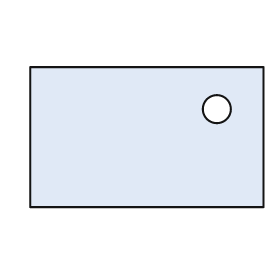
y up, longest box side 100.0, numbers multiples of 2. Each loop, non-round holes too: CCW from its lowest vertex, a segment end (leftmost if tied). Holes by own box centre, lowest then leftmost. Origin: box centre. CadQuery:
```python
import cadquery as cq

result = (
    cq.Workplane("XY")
    .moveTo(-50.0, -30.0)
    .lineTo(50.0, -30.0)
    .lineTo(50.0, 30.0)
    .lineTo(-50.0, 30.0)
    .close()
    .moveTo(30.0, 12.0)
    .circle(6.0)
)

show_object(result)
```